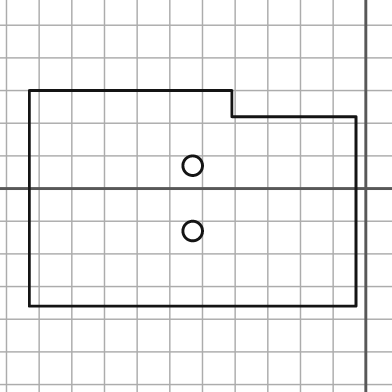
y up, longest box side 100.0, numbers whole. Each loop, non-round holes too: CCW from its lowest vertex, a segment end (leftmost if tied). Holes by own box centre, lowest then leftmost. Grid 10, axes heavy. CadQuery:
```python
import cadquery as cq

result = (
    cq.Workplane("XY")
    .moveTo(-103.0, -36.0)
    .lineTo(-3.0, -36.0)
    .lineTo(-3.0, 22.0)
    .lineTo(-41.0, 22.0)
    .lineTo(-41.0, 30.0)
    .lineTo(-103.0, 30.0)
    .close()
    .moveTo(-53.0, -13.0)
    .circle(3.0)
    .moveTo(-53.0, 7.0)
    .circle(3.0)
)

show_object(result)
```